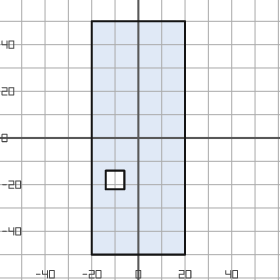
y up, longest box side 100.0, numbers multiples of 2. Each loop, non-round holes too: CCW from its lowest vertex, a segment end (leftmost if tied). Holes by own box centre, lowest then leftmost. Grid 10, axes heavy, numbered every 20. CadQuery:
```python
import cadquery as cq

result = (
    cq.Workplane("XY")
    .moveTo(-20.0, -50.0)
    .lineTo(20.0, -50.0)
    .lineTo(20.0, 50.0)
    .lineTo(-20.0, 50.0)
    .close()
    .moveTo(-14.0, -22.0)
    .lineTo(-6.0, -22.0)
    .lineTo(-6.0, -14.0)
    .lineTo(-14.0, -14.0)
    .close()
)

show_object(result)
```